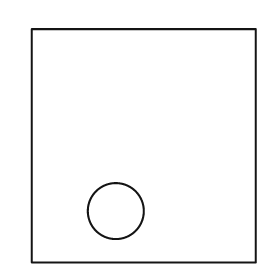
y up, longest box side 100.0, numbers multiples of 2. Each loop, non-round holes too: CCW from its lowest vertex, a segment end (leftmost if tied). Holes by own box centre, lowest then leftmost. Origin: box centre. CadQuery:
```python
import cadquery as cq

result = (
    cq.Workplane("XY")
    .moveTo(-48.0, -50.0)
    .lineTo(48.0, -50.0)
    .lineTo(48.0, 50.0)
    .lineTo(-48.0, 50.0)
    .close()
    .moveTo(-12.0, -28.0)
    .circle(12.0)
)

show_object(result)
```